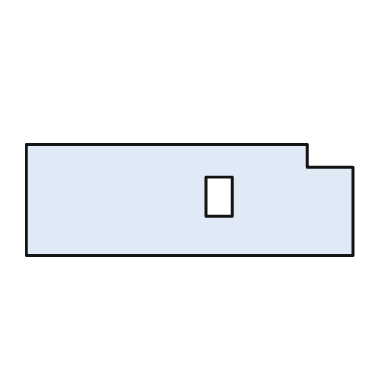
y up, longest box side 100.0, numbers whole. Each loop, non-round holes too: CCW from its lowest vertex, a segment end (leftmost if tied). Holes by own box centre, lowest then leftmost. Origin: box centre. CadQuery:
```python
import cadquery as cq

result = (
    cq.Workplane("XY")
    .moveTo(-50.0, -17.0)
    .lineTo(50.0, -17.0)
    .lineTo(50.0, 10.0)
    .lineTo(36.0, 10.0)
    .lineTo(36.0, 17.0)
    .lineTo(-50.0, 17.0)
    .close()
    .moveTo(5.0, -5.0)
    .lineTo(13.0, -5.0)
    .lineTo(13.0, 7.0)
    .lineTo(5.0, 7.0)
    .close()
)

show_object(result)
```